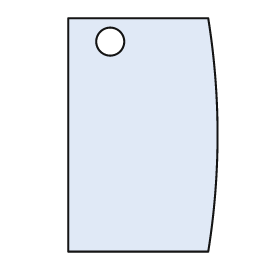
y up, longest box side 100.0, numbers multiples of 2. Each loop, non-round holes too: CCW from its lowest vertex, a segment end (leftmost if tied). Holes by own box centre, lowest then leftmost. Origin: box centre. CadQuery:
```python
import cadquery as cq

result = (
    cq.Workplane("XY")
    .moveTo(-32.0, -50.0)
    .lineTo(28.0, -50.0)
    .threePointArc((32.0, 0.0), (28.0, 50.0))
    .lineTo(-32.0, 50.0)
    .close()
    .moveTo(-14.0, 40.0)
    .circle(6.0)
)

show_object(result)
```